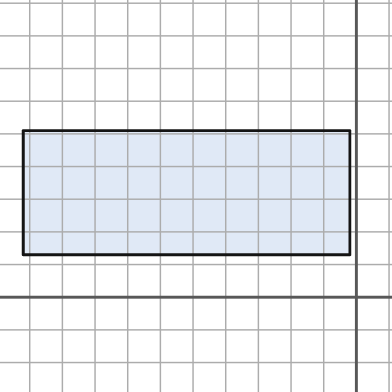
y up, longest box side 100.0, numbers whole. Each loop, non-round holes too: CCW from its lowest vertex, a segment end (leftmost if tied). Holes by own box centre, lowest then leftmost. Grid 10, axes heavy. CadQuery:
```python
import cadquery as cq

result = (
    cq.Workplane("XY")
    .moveTo(-102.0, 13.0)
    .lineTo(-2.0, 13.0)
    .lineTo(-2.0, 51.0)
    .lineTo(-102.0, 51.0)
    .close()
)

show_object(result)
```